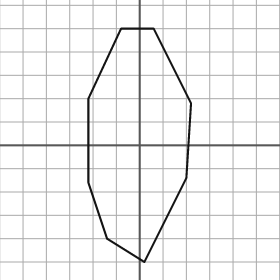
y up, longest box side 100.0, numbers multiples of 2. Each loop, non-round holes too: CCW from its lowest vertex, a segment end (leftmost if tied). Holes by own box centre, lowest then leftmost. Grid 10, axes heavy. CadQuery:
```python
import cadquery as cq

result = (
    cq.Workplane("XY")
    .moveTo(2.0, -50.0)
    .lineTo(20.0, -14.0)
    .lineTo(22.0, 18.0)
    .lineTo(6.0, 50.0)
    .lineTo(-8.0, 50.0)
    .lineTo(-22.0, 20.0)
    .lineTo(-22.0, -16.0)
    .lineTo(-14.0, -40.0)
    .close()
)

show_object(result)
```